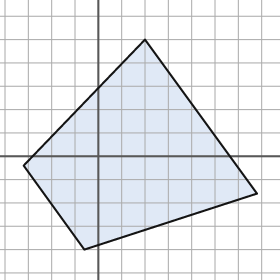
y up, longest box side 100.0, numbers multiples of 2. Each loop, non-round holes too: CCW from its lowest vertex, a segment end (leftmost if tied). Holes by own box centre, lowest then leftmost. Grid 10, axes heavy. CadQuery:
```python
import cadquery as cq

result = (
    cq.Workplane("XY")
    .moveTo(-6.0, -40.0)
    .lineTo(68.0, -16.0)
    .lineTo(20.0, 50.0)
    .lineTo(-32.0, -4.0)
    .close()
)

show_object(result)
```